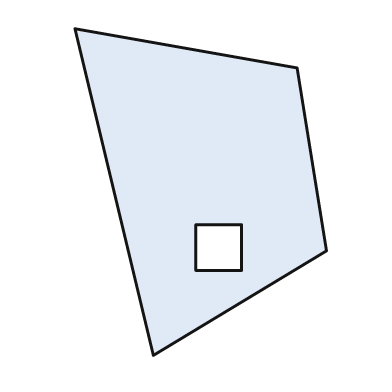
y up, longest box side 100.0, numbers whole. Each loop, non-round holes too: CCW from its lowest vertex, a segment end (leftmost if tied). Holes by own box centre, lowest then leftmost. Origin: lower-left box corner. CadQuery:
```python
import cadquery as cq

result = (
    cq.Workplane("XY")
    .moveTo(24.0, 0.0)
    .lineTo(77.0, 32.0)
    .lineTo(68.0, 88.0)
    .lineTo(0.0, 100.0)
    .close()
    .moveTo(37.0, 26.0)
    .lineTo(51.0, 26.0)
    .lineTo(51.0, 40.0)
    .lineTo(37.0, 40.0)
    .close()
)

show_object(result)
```